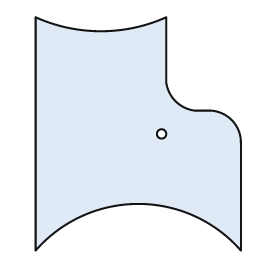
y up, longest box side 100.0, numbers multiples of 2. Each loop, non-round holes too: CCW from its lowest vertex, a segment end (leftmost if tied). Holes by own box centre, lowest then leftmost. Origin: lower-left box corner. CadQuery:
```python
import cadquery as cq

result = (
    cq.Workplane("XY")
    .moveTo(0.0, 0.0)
    .threePointArc((44.0, 20.0), (88.0, 0.0))
    .lineTo(88.0, 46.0)
    .threePointArc((84.0, 56.0), (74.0, 60.0))
    .lineTo(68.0, 60.0)
    .threePointArc((60.0, 64.0), (56.0, 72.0))
    .lineTo(56.0, 100.0)
    .threePointArc((28.0, 94.0), (0.0, 100.0))
    .close()
    .moveTo(54.0, 50.0)
    .circle(2.0)
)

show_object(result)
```